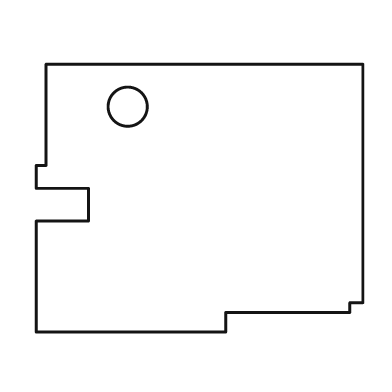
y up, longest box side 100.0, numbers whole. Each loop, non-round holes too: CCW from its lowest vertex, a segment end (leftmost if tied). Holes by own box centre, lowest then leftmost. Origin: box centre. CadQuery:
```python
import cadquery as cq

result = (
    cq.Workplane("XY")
    .moveTo(-50.0, -41.0)
    .lineTo(8.0, -41.0)
    .lineTo(8.0, -35.0)
    .lineTo(46.0, -35.0)
    .lineTo(46.0, -32.0)
    .lineTo(50.0, -32.0)
    .lineTo(50.0, 41.0)
    .lineTo(-47.0, 41.0)
    .lineTo(-47.0, 10.0)
    .lineTo(-50.0, 10.0)
    .lineTo(-50.0, 3.0)
    .lineTo(-34.0, 3.0)
    .lineTo(-34.0, -7.0)
    .lineTo(-50.0, -7.0)
    .close()
    .moveTo(-22.0, 28.0)
    .circle(6.0)
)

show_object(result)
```